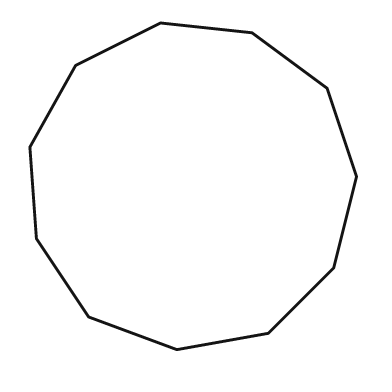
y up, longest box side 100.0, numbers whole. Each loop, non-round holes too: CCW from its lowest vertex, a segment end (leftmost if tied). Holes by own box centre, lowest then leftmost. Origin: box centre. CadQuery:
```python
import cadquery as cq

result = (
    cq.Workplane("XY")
    .moveTo(-5.0, -50.0)
    .lineTo(23.0, -45.0)
    .lineTo(43.0, -25.0)
    .lineTo(50.0, 3.0)
    .lineTo(41.0, 30.0)
    .lineTo(18.0, 47.0)
    .lineTo(-10.0, 50.0)
    .lineTo(-36.0, 37.0)
    .lineTo(-50.0, 12.0)
    .lineTo(-48.0, -16.0)
    .lineTo(-32.0, -40.0)
    .close()
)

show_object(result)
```